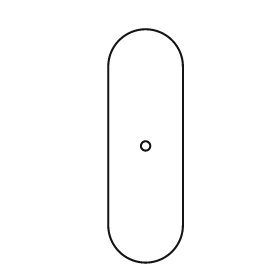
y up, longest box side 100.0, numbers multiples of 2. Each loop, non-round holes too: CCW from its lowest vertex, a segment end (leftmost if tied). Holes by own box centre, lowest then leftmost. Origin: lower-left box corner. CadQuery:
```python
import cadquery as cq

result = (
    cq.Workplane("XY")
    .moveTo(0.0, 16.0)
    .threePointArc((16.0, 0.0), (32.0, 16.0))
    .lineTo(32.0, 84.0)
    .threePointArc((16.0, 100.0), (0.0, 84.0))
    .close()
    .moveTo(16.0, 50.0)
    .circle(2.0)
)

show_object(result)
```